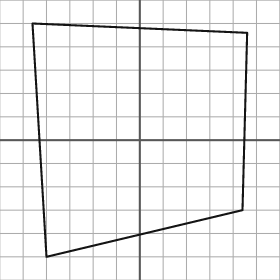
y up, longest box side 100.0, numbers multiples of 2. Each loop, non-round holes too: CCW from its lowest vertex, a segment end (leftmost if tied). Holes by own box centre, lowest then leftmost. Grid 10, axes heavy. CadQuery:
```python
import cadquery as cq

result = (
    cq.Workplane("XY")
    .moveTo(-40.0, -50.0)
    .lineTo(44.0, -30.0)
    .lineTo(46.0, 46.0)
    .lineTo(-46.0, 50.0)
    .close()
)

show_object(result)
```